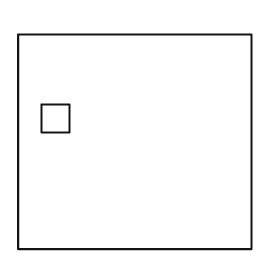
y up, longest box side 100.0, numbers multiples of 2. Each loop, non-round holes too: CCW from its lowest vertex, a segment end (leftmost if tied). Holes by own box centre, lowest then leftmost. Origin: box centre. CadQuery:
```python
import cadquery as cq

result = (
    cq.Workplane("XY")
    .moveTo(-50.0, -46.0)
    .lineTo(50.0, -46.0)
    .lineTo(50.0, 46.0)
    .lineTo(-50.0, 46.0)
    .close()
    .moveTo(-40.0, 4.0)
    .lineTo(-28.0, 4.0)
    .lineTo(-28.0, 16.0)
    .lineTo(-40.0, 16.0)
    .close()
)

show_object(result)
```